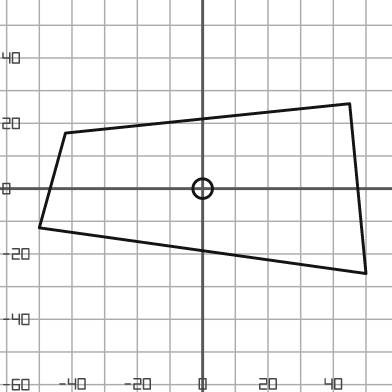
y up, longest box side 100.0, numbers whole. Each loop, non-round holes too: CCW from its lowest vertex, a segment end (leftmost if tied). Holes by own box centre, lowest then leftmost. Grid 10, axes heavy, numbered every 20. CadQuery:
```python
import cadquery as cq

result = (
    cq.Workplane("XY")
    .moveTo(50.0, -26.0)
    .lineTo(45.0, 26.0)
    .lineTo(-42.0, 17.0)
    .lineTo(-50.0, -12.0)
    .close()
    .moveTo(0.0, 0.0)
    .circle(3.0)
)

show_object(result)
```